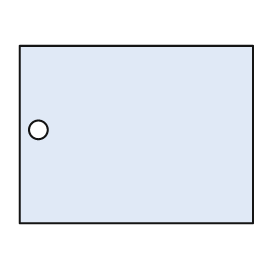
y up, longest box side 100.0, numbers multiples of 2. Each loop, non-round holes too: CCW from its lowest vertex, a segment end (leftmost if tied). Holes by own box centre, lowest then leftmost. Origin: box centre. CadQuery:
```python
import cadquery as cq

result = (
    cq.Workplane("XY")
    .moveTo(-50.0, -38.0)
    .lineTo(50.0, -38.0)
    .lineTo(50.0, 38.0)
    .lineTo(-50.0, 38.0)
    .close()
    .moveTo(-42.0, 2.0)
    .circle(4.0)
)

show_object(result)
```